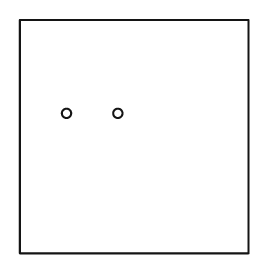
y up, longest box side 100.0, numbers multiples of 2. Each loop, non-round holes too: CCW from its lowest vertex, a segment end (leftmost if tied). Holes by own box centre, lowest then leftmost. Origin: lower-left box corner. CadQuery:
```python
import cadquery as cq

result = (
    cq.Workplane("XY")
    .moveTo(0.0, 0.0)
    .lineTo(98.0, 0.0)
    .lineTo(98.0, 100.0)
    .lineTo(0.0, 100.0)
    .close()
    .moveTo(20.0, 60.0)
    .circle(2.0)
    .moveTo(42.0, 60.0)
    .circle(2.0)
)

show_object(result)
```